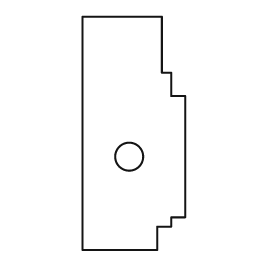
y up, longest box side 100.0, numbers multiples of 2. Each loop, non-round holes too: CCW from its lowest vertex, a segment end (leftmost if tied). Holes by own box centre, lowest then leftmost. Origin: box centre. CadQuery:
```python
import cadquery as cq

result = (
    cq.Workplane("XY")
    .moveTo(-22.0, -50.0)
    .lineTo(10.0, -50.0)
    .lineTo(10.0, -40.0)
    .lineTo(16.0, -40.0)
    .lineTo(16.0, -36.0)
    .lineTo(22.0, -36.0)
    .lineTo(22.0, 16.0)
    .lineTo(16.0, 16.0)
    .lineTo(16.0, 26.0)
    .lineTo(12.0, 26.0)
    .lineTo(12.0, 50.0)
    .lineTo(-22.0, 50.0)
    .close()
    .moveTo(-2.0, -10.0)
    .circle(6.0)
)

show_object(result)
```